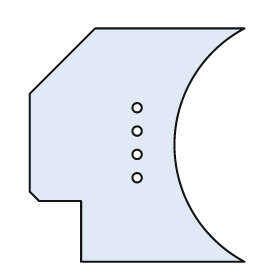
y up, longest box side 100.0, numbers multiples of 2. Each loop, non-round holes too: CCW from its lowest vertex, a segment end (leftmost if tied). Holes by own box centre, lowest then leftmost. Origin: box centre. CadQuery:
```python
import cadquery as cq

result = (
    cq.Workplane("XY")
    .moveTo(-24.0, -50.0)
    .lineTo(46.0, -50.0)
    .threePointArc((16.0, 0.0), (46.0, 50.0))
    .lineTo(-18.0, 50.0)
    .lineTo(-46.0, 22.0)
    .lineTo(-46.0, -20.0)
    .lineTo(-42.0, -24.0)
    .lineTo(-24.0, -24.0)
    .close()
    .moveTo(0.0, -14.0)
    .circle(2.0)
    .moveTo(0.0, -4.0)
    .circle(2.0)
    .moveTo(0.0, 6.0)
    .circle(2.0)
    .moveTo(0.0, 16.0)
    .circle(2.0)
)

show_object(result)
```